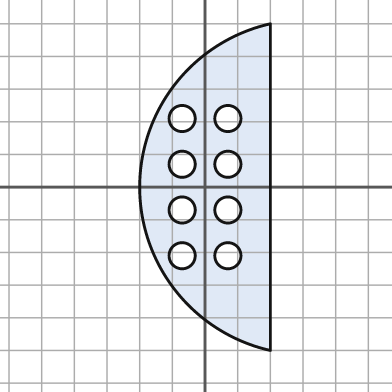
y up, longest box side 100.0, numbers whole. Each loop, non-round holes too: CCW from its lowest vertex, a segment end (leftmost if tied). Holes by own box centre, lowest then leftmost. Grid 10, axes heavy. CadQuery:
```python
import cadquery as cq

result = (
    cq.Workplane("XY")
    .moveTo(20.0, -50.0)
    .lineTo(20.0, 50.0)
    .threePointArc((-20.0, 0.0), (20.0, -50.0))
    .close()
    .moveTo(-7.0, -21.0)
    .circle(4.0)
    .moveTo(7.0, -21.0)
    .circle(4.0)
    .moveTo(-7.0, -7.0)
    .circle(4.0)
    .moveTo(7.0, -7.0)
    .circle(4.0)
    .moveTo(-7.0, 7.0)
    .circle(4.0)
    .moveTo(7.0, 7.0)
    .circle(4.0)
    .moveTo(-7.0, 21.0)
    .circle(4.0)
    .moveTo(7.0, 21.0)
    .circle(4.0)
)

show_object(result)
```